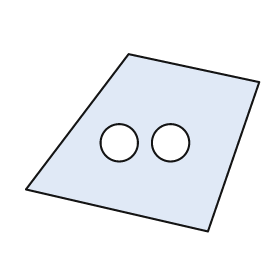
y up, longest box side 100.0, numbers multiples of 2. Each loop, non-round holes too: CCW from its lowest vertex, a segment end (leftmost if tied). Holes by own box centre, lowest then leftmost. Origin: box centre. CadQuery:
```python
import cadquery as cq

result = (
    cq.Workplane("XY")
    .moveTo(28.0, -38.0)
    .lineTo(50.0, 26.0)
    .lineTo(-6.0, 38.0)
    .lineTo(-50.0, -20.0)
    .close()
    .moveTo(-10.0, 0.0)
    .circle(8.0)
    .moveTo(12.0, 0.0)
    .circle(8.0)
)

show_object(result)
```